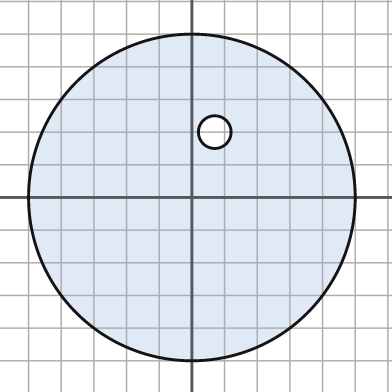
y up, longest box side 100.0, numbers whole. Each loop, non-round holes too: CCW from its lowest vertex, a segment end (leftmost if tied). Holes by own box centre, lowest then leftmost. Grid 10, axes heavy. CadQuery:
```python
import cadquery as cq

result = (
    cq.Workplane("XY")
    .moveTo(0.0, 0.0)
    .circle(50.0)
    .moveTo(7.0, 20.0)
    .circle(5.0)
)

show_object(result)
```